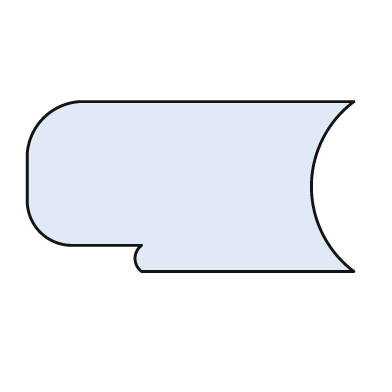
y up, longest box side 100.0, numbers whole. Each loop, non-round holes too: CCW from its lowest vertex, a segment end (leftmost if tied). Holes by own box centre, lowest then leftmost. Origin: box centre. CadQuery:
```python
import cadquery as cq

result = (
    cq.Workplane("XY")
    .moveTo(-15.0, -26.0)
    .lineTo(50.0, -26.0)
    .threePointArc((37.0, 0.0), (50.0, 26.0))
    .lineTo(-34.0, 26.0)
    .threePointArc((-45.0, 21.0), (-50.0, 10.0))
    .lineTo(-50.0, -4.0)
    .threePointArc((-46.0, -14.0), (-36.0, -18.0))
    .lineTo(-15.0, -18.0)
    .threePointArc((-17.0, -22.0), (-15.0, -26.0))
    .close()
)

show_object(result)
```